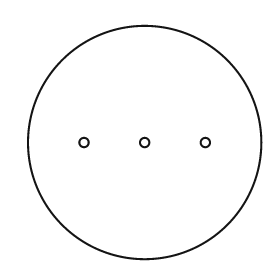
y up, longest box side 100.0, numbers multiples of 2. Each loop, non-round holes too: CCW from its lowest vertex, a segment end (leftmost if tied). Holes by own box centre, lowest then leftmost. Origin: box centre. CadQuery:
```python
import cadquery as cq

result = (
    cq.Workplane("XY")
    .moveTo(0.0, 0.0)
    .circle(50.0)
    .moveTo(-26.0, 0.0)
    .circle(2.0)
    .moveTo(0.0, 0.0)
    .circle(2.0)
    .moveTo(26.0, 0.0)
    .circle(2.0)
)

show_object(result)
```